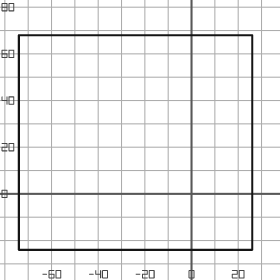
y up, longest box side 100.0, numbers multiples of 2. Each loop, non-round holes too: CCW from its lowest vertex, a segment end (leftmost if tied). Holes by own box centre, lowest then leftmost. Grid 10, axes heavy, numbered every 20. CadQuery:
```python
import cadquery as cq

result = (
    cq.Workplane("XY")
    .moveTo(-74.0, -24.0)
    .lineTo(26.0, -24.0)
    .lineTo(26.0, 68.0)
    .lineTo(-74.0, 68.0)
    .close()
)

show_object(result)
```